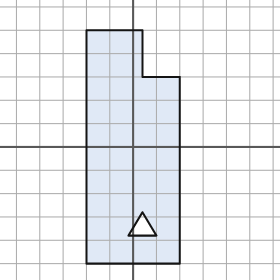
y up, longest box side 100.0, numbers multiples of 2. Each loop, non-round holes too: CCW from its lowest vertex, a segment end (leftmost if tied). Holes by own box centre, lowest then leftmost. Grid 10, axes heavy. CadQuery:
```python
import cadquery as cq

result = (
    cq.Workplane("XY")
    .moveTo(-20.0, -50.0)
    .lineTo(20.0, -50.0)
    .lineTo(20.0, 30.0)
    .lineTo(4.0, 30.0)
    .lineTo(4.0, 50.0)
    .lineTo(-20.0, 50.0)
    .close()
    .moveTo(-2.0, -38.0)
    .lineTo(10.0, -38.0)
    .lineTo(4.0, -28.0)
    .close()
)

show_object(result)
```